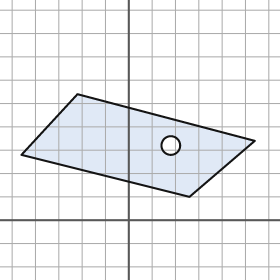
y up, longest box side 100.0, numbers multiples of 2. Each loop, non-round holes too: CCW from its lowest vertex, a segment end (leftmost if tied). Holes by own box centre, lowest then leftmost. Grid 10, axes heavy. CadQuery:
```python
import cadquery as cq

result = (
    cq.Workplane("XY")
    .moveTo(26.0, 10.0)
    .lineTo(54.0, 34.0)
    .lineTo(-22.0, 54.0)
    .lineTo(-46.0, 28.0)
    .close()
    .moveTo(18.0, 32.0)
    .circle(4.0)
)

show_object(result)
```